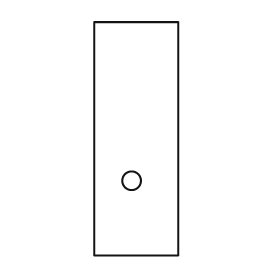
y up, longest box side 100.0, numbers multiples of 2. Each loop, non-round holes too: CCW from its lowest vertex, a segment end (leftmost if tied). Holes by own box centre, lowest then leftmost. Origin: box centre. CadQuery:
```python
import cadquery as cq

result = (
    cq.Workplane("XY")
    .moveTo(-18.0, -50.0)
    .lineTo(18.0, -50.0)
    .lineTo(18.0, 50.0)
    .lineTo(-18.0, 50.0)
    .close()
    .moveTo(-2.0, -18.0)
    .circle(4.0)
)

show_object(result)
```